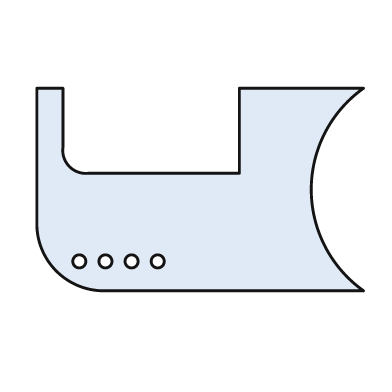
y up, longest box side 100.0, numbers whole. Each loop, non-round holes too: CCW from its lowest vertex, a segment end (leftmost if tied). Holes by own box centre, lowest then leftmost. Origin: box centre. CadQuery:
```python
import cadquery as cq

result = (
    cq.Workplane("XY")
    .moveTo(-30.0, -31.0)
    .lineTo(50.0, -31.0)
    .threePointArc((34.0, 0.0), (50.0, 31.0))
    .lineTo(12.0, 31.0)
    .lineTo(12.0, 5.0)
    .lineTo(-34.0, 5.0)
    .threePointArc((-40.0, 7.0), (-42.0, 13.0))
    .lineTo(-42.0, 31.0)
    .lineTo(-50.0, 31.0)
    .lineTo(-50.0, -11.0)
    .threePointArc((-44.0, -25.0), (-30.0, -31.0))
    .close()
    .moveTo(-37.0, -22.0)
    .circle(2.0)
    .moveTo(-29.0, -22.0)
    .circle(2.0)
    .moveTo(-21.0, -22.0)
    .circle(2.0)
    .moveTo(-13.0, -22.0)
    .circle(2.0)
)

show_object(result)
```